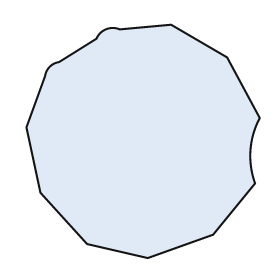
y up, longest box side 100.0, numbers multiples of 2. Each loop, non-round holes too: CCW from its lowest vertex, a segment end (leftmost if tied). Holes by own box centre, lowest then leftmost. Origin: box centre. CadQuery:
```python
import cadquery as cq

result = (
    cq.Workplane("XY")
    .moveTo(2.0, -50.0)
    .lineTo(30.0, -40.0)
    .lineTo(48.0, -18.0)
    .threePointArc((46.0, -4.0), (50.0, 10.0))
    .lineTo(36.0, 36.0)
    .lineTo(12.0, 50.0)
    .lineTo(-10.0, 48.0)
    .threePointArc((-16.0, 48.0), (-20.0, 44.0))
    .lineTo(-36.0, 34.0)
    .threePointArc((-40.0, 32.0), (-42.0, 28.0))
    .lineTo(-50.0, 6.0)
    .lineTo(-44.0, -22.0)
    .lineTo(-24.0, -44.0)
    .close()
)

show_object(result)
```